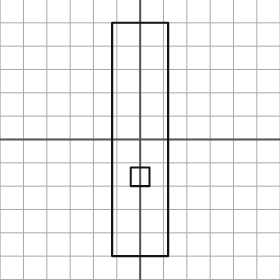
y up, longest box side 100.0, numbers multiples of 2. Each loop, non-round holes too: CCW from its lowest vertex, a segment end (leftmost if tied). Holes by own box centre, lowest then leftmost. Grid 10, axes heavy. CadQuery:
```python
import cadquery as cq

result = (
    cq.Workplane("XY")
    .moveTo(-12.0, -50.0)
    .lineTo(12.0, -50.0)
    .lineTo(12.0, 50.0)
    .lineTo(-12.0, 50.0)
    .close()
    .moveTo(-4.0, -20.0)
    .lineTo(4.0, -20.0)
    .lineTo(4.0, -12.0)
    .lineTo(-4.0, -12.0)
    .close()
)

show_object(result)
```